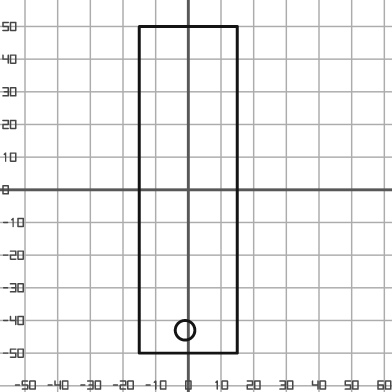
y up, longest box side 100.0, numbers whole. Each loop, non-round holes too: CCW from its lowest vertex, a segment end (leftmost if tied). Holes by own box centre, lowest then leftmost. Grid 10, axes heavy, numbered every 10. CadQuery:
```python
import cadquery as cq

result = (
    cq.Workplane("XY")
    .moveTo(-15.0, -50.0)
    .lineTo(15.0, -50.0)
    .lineTo(15.0, 50.0)
    .lineTo(-15.0, 50.0)
    .close()
    .moveTo(-1.0, -43.0)
    .circle(3.0)
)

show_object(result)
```